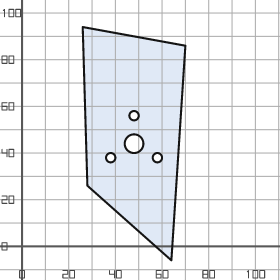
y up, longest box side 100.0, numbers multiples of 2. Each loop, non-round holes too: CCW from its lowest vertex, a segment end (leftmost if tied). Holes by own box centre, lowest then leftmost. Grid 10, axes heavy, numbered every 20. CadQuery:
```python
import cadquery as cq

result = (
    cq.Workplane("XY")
    .moveTo(64.0, -6.0)
    .lineTo(70.0, 86.0)
    .lineTo(26.0, 94.0)
    .lineTo(28.0, 26.0)
    .close()
    .moveTo(38.0, 38.0)
    .circle(2.0)
    .moveTo(58.0, 38.0)
    .circle(2.0)
    .moveTo(48.0, 44.0)
    .circle(4.0)
    .moveTo(48.0, 56.0)
    .circle(2.0)
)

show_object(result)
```